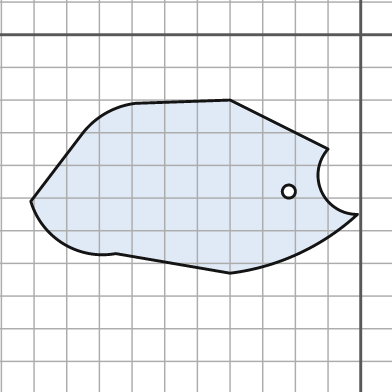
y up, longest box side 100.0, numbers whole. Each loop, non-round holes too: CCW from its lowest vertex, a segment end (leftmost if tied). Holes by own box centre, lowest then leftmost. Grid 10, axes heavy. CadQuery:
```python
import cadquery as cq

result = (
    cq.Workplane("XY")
    .moveTo(-40.0, -73.0)
    .threePointArc((-19.0, -67.0), (-1.0, -55.0))
    .threePointArc((-12.0, -48.0), (-10.0, -35.0))
    .lineTo(-40.0, -20.0)
    .lineTo(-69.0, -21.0)
    .threePointArc((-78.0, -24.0), (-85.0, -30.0))
    .lineTo(-101.0, -51.0)
    .threePointArc((-91.0, -64.0), (-75.0, -67.0))
    .close()
    .moveTo(-22.0, -48.0)
    .circle(2.0)
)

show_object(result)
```